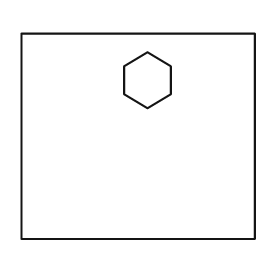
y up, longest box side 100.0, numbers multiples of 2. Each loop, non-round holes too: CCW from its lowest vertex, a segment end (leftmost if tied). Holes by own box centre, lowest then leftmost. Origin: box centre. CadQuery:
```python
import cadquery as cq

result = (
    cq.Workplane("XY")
    .moveTo(-50.0, -44.0)
    .lineTo(50.0, -44.0)
    .lineTo(50.0, 44.0)
    .lineTo(-50.0, 44.0)
    .close()
    .moveTo(4.0, 12.0)
    .lineTo(14.0, 18.0)
    .lineTo(14.0, 30.0)
    .lineTo(4.0, 36.0)
    .lineTo(-6.0, 30.0)
    .lineTo(-6.0, 18.0)
    .close()
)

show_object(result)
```